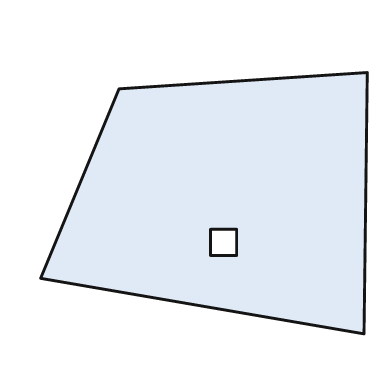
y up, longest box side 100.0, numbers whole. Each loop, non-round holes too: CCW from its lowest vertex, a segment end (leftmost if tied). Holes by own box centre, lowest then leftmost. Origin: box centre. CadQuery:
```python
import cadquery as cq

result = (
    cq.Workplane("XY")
    .moveTo(49.0, -40.0)
    .lineTo(50.0, 40.0)
    .lineTo(-26.0, 35.0)
    .lineTo(-50.0, -23.0)
    .close()
    .moveTo(2.0, -16.0)
    .lineTo(10.0, -16.0)
    .lineTo(10.0, -8.0)
    .lineTo(2.0, -8.0)
    .close()
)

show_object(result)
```